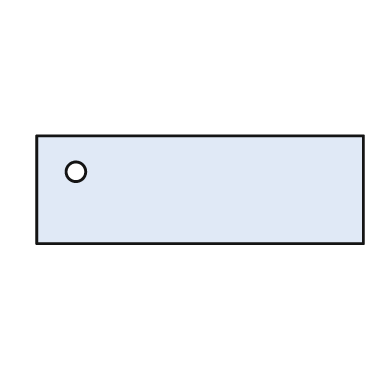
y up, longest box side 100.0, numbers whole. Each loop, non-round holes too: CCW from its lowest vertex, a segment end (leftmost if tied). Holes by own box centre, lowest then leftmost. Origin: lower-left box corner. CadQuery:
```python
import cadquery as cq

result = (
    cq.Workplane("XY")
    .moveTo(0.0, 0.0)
    .lineTo(100.0, 0.0)
    .lineTo(100.0, 33.0)
    .lineTo(0.0, 33.0)
    .close()
    .moveTo(12.0, 22.0)
    .circle(3.0)
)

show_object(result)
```